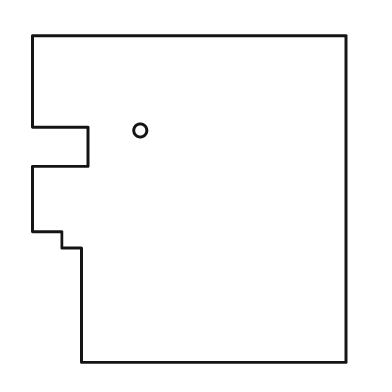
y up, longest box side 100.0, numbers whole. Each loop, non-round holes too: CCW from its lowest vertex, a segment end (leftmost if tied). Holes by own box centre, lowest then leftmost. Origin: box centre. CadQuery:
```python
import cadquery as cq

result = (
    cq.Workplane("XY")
    .moveTo(-33.0, -50.0)
    .lineTo(48.0, -50.0)
    .lineTo(48.0, 50.0)
    .lineTo(-48.0, 50.0)
    .lineTo(-48.0, 22.0)
    .lineTo(-31.0, 22.0)
    .lineTo(-31.0, 10.0)
    .lineTo(-48.0, 10.0)
    .lineTo(-48.0, -10.0)
    .lineTo(-39.0, -10.0)
    .lineTo(-39.0, -15.0)
    .lineTo(-33.0, -15.0)
    .close()
    .moveTo(-15.0, 21.0)
    .circle(2.0)
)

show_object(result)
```